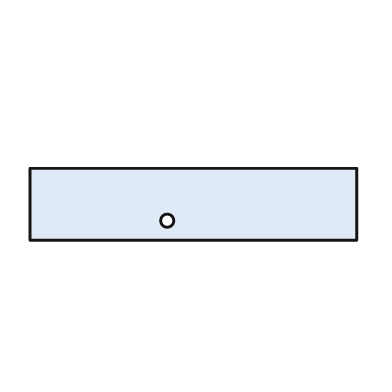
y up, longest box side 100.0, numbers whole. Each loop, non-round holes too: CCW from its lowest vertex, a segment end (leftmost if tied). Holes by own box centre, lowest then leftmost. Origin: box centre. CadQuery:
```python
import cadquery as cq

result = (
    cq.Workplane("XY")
    .moveTo(-50.0, -11.0)
    .lineTo(50.0, -11.0)
    .lineTo(50.0, 11.0)
    .lineTo(-50.0, 11.0)
    .close()
    .moveTo(-8.0, -5.0)
    .circle(2.0)
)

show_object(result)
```